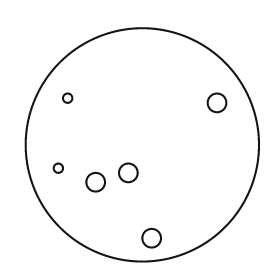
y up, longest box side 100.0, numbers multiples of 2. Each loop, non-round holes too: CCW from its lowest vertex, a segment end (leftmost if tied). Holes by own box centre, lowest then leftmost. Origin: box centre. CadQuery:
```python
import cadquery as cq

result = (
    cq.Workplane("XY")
    .moveTo(0.0, 0.0)
    .circle(50.0)
    .moveTo(4.0, -40.0)
    .circle(4.0)
    .moveTo(-20.0, -16.0)
    .circle(4.0)
    .moveTo(-6.0, -12.0)
    .circle(4.0)
    .moveTo(-36.0, -10.0)
    .circle(2.0)
    .moveTo(32.0, 18.0)
    .circle(4.0)
    .moveTo(-32.0, 20.0)
    .circle(2.0)
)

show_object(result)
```